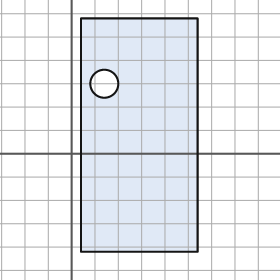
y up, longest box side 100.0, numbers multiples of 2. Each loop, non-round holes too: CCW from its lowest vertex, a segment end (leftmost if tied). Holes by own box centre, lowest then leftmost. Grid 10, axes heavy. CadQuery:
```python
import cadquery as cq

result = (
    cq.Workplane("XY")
    .moveTo(4.0, -42.0)
    .lineTo(54.0, -42.0)
    .lineTo(54.0, 58.0)
    .lineTo(4.0, 58.0)
    .close()
    .moveTo(14.0, 30.0)
    .circle(6.0)
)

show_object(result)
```